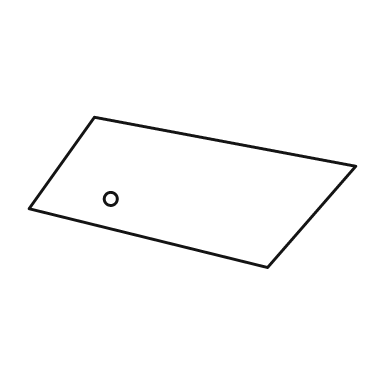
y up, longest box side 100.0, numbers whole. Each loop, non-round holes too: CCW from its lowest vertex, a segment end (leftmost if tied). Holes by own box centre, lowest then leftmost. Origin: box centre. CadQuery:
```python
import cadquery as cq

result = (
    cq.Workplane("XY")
    .moveTo(23.0, -23.0)
    .lineTo(50.0, 8.0)
    .lineTo(-30.0, 23.0)
    .lineTo(-50.0, -5.0)
    .close()
    .moveTo(-25.0, -2.0)
    .circle(2.0)
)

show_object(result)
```